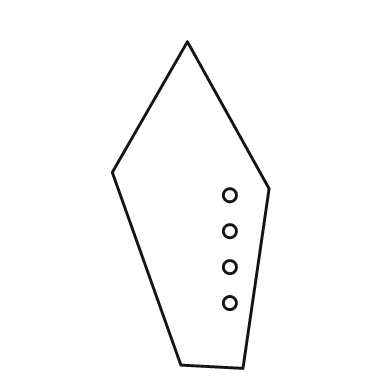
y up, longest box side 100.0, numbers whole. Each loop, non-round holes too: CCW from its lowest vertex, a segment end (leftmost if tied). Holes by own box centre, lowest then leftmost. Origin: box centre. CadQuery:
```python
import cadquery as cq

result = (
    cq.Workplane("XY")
    .moveTo(16.0, -50.0)
    .lineTo(24.0, 5.0)
    .lineTo(-1.0, 50.0)
    .lineTo(-24.0, 10.0)
    .lineTo(-3.0, -49.0)
    .close()
    .moveTo(12.0, -30.0)
    .circle(2.0)
    .moveTo(12.0, -19.0)
    .circle(2.0)
    .moveTo(12.0, -8.0)
    .circle(2.0)
    .moveTo(12.0, 3.0)
    .circle(2.0)
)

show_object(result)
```